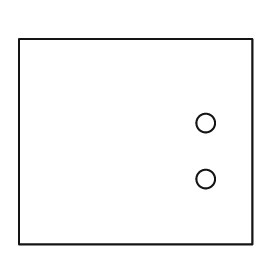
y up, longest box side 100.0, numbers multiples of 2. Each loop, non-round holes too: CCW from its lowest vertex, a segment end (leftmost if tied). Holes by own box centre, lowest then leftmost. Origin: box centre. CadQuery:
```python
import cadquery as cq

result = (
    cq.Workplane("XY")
    .moveTo(-50.0, -44.0)
    .lineTo(50.0, -44.0)
    .lineTo(50.0, 44.0)
    .lineTo(-50.0, 44.0)
    .close()
    .moveTo(30.0, -16.0)
    .circle(4.0)
    .moveTo(30.0, 8.0)
    .circle(4.0)
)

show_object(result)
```